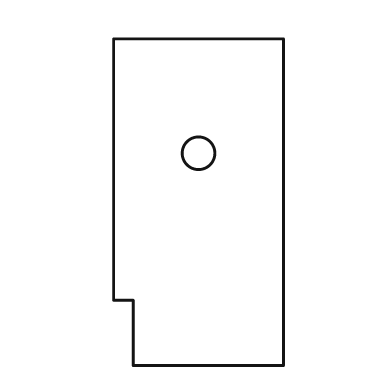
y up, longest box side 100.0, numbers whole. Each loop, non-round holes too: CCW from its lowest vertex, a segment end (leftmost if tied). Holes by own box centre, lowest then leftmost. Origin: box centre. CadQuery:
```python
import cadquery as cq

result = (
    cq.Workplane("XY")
    .moveTo(-20.0, -50.0)
    .lineTo(26.0, -50.0)
    .lineTo(26.0, 50.0)
    .lineTo(-26.0, 50.0)
    .lineTo(-26.0, -30.0)
    .lineTo(-20.0, -30.0)
    .close()
    .moveTo(0.0, 15.0)
    .circle(5.0)
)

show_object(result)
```